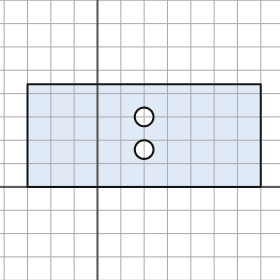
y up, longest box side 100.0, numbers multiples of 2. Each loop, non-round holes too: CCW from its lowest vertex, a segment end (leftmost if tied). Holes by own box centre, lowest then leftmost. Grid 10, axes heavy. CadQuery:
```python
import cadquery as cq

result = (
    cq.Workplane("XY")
    .moveTo(-30.0, 0.0)
    .lineTo(70.0, 0.0)
    .lineTo(70.0, 44.0)
    .lineTo(-30.0, 44.0)
    .close()
    .moveTo(20.0, 16.0)
    .circle(4.0)
    .moveTo(20.0, 30.0)
    .circle(4.0)
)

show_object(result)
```